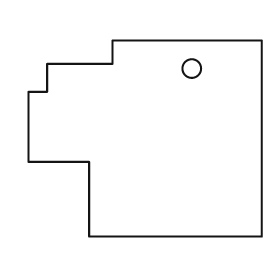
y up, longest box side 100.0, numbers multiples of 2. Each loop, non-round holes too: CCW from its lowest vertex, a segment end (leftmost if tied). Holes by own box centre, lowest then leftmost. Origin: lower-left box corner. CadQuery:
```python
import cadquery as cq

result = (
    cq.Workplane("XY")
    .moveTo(26.0, 0.0)
    .lineTo(100.0, 0.0)
    .lineTo(100.0, 84.0)
    .lineTo(36.0, 84.0)
    .lineTo(36.0, 74.0)
    .lineTo(8.0, 74.0)
    .lineTo(8.0, 62.0)
    .lineTo(0.0, 62.0)
    .lineTo(0.0, 32.0)
    .lineTo(26.0, 32.0)
    .close()
    .moveTo(70.0, 72.0)
    .circle(4.0)
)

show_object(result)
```